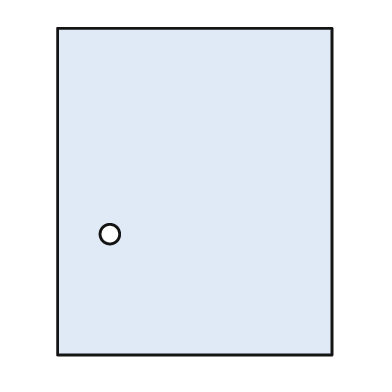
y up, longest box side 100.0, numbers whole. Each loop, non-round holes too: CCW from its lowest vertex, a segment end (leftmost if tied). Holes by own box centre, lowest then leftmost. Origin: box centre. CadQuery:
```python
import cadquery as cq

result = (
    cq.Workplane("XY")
    .moveTo(-42.0, -50.0)
    .lineTo(42.0, -50.0)
    .lineTo(42.0, 50.0)
    .lineTo(-42.0, 50.0)
    .close()
    .moveTo(-26.0, -13.0)
    .circle(3.0)
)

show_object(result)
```